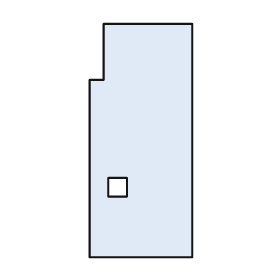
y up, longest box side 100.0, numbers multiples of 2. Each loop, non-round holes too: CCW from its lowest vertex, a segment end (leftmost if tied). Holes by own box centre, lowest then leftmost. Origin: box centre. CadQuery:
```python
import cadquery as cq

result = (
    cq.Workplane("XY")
    .moveTo(-22.0, -50.0)
    .lineTo(22.0, -50.0)
    .lineTo(22.0, 50.0)
    .lineTo(-16.0, 50.0)
    .lineTo(-16.0, 26.0)
    .lineTo(-22.0, 26.0)
    .close()
    .moveTo(-14.0, -24.0)
    .lineTo(-6.0, -24.0)
    .lineTo(-6.0, -16.0)
    .lineTo(-14.0, -16.0)
    .close()
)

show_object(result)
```